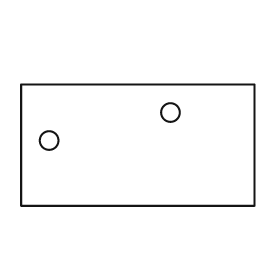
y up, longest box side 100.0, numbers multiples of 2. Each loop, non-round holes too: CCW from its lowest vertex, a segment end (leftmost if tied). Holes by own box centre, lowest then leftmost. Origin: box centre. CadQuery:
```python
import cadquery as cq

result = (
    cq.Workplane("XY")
    .moveTo(-50.0, -26.0)
    .lineTo(50.0, -26.0)
    .lineTo(50.0, 26.0)
    .lineTo(-50.0, 26.0)
    .close()
    .moveTo(-38.0, 2.0)
    .circle(4.0)
    .moveTo(14.0, 14.0)
    .circle(4.0)
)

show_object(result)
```